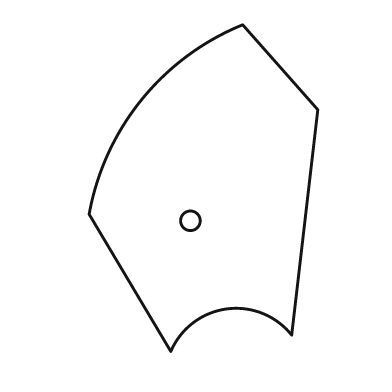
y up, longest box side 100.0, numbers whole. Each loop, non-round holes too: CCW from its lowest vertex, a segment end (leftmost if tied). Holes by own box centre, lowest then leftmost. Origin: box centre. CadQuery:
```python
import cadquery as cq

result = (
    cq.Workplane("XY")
    .moveTo(-10.0, -50.0)
    .threePointArc((7.0, -37.0), (27.0, -45.0))
    .lineTo(35.0, 24.0)
    .lineTo(12.0, 50.0)
    .threePointArc((-19.0, 27.0), (-35.0, -8.0))
    .close()
    .moveTo(-4.0, -10.0)
    .circle(3.0)
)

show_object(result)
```